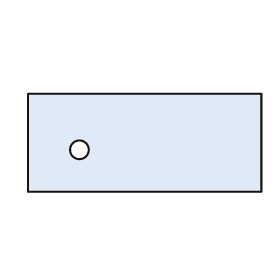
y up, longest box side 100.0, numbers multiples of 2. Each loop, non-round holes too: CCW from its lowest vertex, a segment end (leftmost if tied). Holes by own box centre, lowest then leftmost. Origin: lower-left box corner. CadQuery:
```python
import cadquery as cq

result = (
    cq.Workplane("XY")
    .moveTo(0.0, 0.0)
    .lineTo(100.0, 0.0)
    .lineTo(100.0, 42.0)
    .lineTo(0.0, 42.0)
    .close()
    .moveTo(22.0, 18.0)
    .circle(4.0)
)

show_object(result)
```